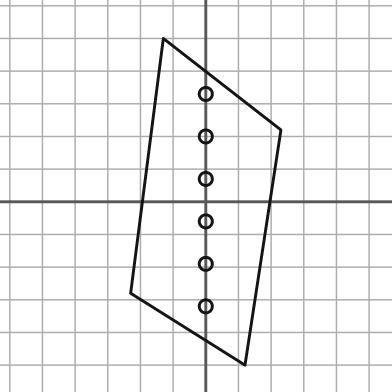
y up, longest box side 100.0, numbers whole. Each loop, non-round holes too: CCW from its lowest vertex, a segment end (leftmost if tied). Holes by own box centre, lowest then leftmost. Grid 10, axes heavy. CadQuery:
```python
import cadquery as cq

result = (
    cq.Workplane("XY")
    .moveTo(12.0, -50.0)
    .lineTo(23.0, 22.0)
    .lineTo(-13.0, 50.0)
    .lineTo(-23.0, -28.0)
    .close()
    .moveTo(0.0, -32.0)
    .circle(2.0)
    .moveTo(0.0, -19.0)
    .circle(2.0)
    .moveTo(0.0, -6.0)
    .circle(2.0)
    .moveTo(0.0, 7.0)
    .circle(2.0)
    .moveTo(0.0, 20.0)
    .circle(2.0)
    .moveTo(0.0, 33.0)
    .circle(2.0)
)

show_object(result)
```